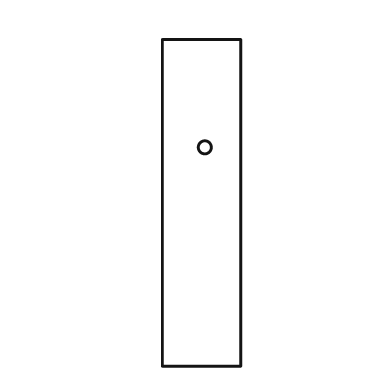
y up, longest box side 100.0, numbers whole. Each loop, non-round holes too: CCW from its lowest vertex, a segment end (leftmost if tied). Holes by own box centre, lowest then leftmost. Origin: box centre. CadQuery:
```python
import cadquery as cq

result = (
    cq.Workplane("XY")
    .moveTo(-12.0, -50.0)
    .lineTo(12.0, -50.0)
    .lineTo(12.0, 50.0)
    .lineTo(-12.0, 50.0)
    .close()
    .moveTo(1.0, 17.0)
    .circle(2.0)
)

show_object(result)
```